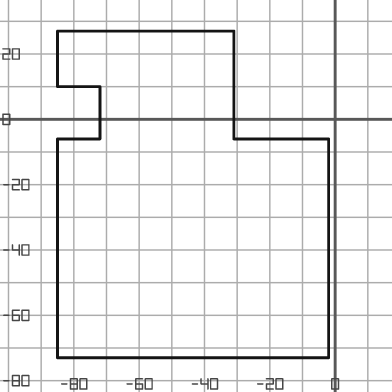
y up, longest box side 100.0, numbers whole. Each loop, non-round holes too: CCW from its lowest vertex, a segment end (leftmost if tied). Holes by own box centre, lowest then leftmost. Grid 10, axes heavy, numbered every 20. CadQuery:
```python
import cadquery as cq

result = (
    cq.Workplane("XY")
    .moveTo(-85.0, -73.0)
    .lineTo(-2.0, -73.0)
    .lineTo(-2.0, -6.0)
    .lineTo(-31.0, -6.0)
    .lineTo(-31.0, 27.0)
    .lineTo(-85.0, 27.0)
    .lineTo(-85.0, 10.0)
    .lineTo(-72.0, 10.0)
    .lineTo(-72.0, -6.0)
    .lineTo(-85.0, -6.0)
    .close()
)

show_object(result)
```